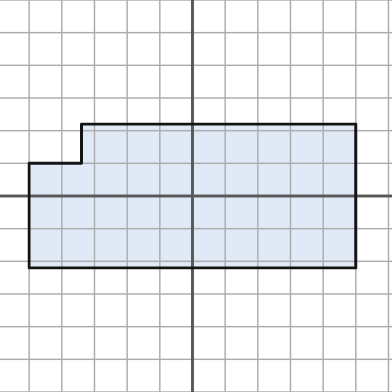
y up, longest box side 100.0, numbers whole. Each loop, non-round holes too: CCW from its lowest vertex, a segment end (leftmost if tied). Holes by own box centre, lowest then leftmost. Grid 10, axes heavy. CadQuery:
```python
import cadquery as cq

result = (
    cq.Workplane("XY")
    .moveTo(-50.0, -22.0)
    .lineTo(50.0, -22.0)
    .lineTo(50.0, 22.0)
    .lineTo(-34.0, 22.0)
    .lineTo(-34.0, 10.0)
    .lineTo(-50.0, 10.0)
    .close()
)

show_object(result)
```